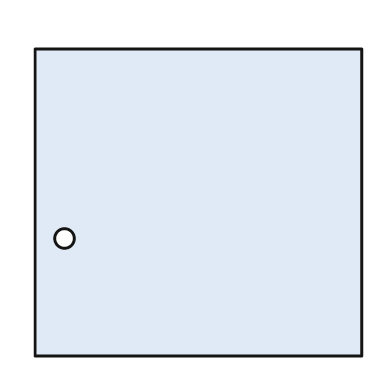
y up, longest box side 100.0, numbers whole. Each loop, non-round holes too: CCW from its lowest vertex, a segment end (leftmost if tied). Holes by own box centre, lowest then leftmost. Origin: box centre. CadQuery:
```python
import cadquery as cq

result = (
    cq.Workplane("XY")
    .moveTo(-50.0, -47.0)
    .lineTo(50.0, -47.0)
    .lineTo(50.0, 47.0)
    .lineTo(-50.0, 47.0)
    .close()
    .moveTo(-41.0, -11.0)
    .circle(3.0)
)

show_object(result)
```